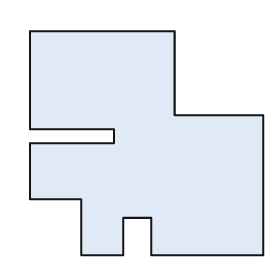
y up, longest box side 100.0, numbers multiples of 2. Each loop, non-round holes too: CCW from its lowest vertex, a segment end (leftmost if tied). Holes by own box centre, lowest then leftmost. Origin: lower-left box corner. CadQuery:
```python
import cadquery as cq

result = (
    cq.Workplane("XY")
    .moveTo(22.0, 0.0)
    .lineTo(40.0, 0.0)
    .lineTo(40.0, 16.0)
    .lineTo(52.0, 16.0)
    .lineTo(52.0, 0.0)
    .lineTo(100.0, 0.0)
    .lineTo(100.0, 60.0)
    .lineTo(62.0, 60.0)
    .lineTo(62.0, 96.0)
    .lineTo(0.0, 96.0)
    .lineTo(0.0, 54.0)
    .lineTo(36.0, 54.0)
    .lineTo(36.0, 48.0)
    .lineTo(0.0, 48.0)
    .lineTo(0.0, 24.0)
    .lineTo(22.0, 24.0)
    .close()
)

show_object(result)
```